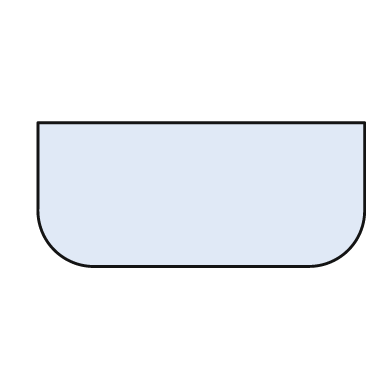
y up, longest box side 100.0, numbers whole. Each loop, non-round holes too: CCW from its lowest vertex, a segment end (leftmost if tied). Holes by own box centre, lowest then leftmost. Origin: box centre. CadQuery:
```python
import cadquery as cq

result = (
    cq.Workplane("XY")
    .moveTo(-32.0, -22.0)
    .lineTo(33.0, -22.0)
    .threePointArc((45.0, -17.0), (50.0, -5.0))
    .lineTo(50.0, 22.0)
    .lineTo(-50.0, 22.0)
    .lineTo(-50.0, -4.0)
    .threePointArc((-45.0, -17.0), (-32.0, -22.0))
    .close()
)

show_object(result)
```